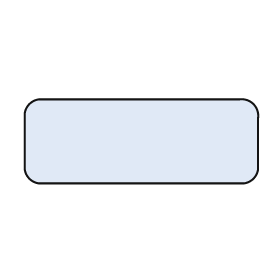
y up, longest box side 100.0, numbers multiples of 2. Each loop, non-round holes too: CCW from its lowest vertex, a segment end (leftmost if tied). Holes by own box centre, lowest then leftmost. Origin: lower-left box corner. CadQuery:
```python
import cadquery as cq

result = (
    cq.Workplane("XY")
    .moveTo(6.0, 0.0)
    .lineTo(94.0, 0.0)
    .threePointArc((98.0, 2.0), (100.0, 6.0))
    .lineTo(100.0, 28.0)
    .threePointArc((98.0, 34.0), (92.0, 36.0))
    .lineTo(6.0, 36.0)
    .threePointArc((2.0, 34.0), (0.0, 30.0))
    .lineTo(0.0, 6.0)
    .threePointArc((2.0, 2.0), (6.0, 0.0))
    .close()
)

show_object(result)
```